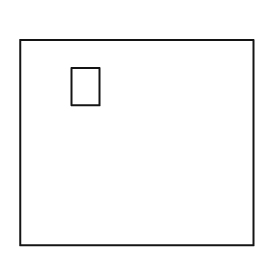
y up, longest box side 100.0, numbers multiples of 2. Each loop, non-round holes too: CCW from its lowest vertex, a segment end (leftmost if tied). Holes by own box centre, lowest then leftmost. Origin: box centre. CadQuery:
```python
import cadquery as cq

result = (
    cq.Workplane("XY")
    .moveTo(-50.0, -44.0)
    .lineTo(50.0, -44.0)
    .lineTo(50.0, 44.0)
    .lineTo(-50.0, 44.0)
    .close()
    .moveTo(-28.0, 16.0)
    .lineTo(-16.0, 16.0)
    .lineTo(-16.0, 32.0)
    .lineTo(-28.0, 32.0)
    .close()
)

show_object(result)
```